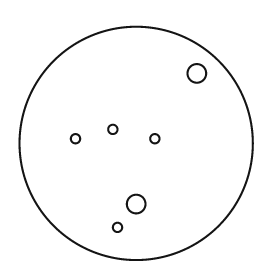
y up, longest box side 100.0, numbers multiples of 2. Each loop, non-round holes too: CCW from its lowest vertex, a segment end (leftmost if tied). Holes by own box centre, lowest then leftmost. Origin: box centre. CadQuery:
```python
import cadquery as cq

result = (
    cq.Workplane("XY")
    .moveTo(0.0, 0.0)
    .circle(50.0)
    .moveTo(-8.0, -36.0)
    .circle(2.0)
    .moveTo(0.0, -26.0)
    .circle(4.0)
    .moveTo(-26.0, 2.0)
    .circle(2.0)
    .moveTo(8.0, 2.0)
    .circle(2.0)
    .moveTo(-10.0, 6.0)
    .circle(2.0)
    .moveTo(26.0, 30.0)
    .circle(4.0)
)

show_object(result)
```